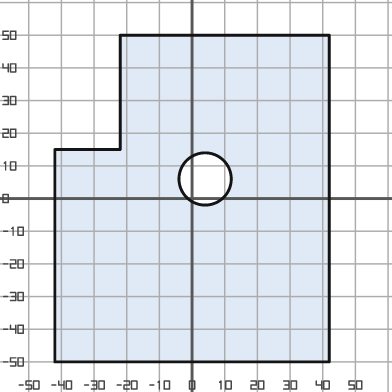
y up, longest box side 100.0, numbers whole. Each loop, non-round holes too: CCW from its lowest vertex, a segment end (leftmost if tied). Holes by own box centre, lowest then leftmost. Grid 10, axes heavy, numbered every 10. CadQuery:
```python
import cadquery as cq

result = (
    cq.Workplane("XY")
    .moveTo(-42.0, -50.0)
    .lineTo(42.0, -50.0)
    .lineTo(42.0, 50.0)
    .lineTo(-22.0, 50.0)
    .lineTo(-22.0, 15.0)
    .lineTo(-42.0, 15.0)
    .close()
    .moveTo(4.0, 6.0)
    .circle(8.0)
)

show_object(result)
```